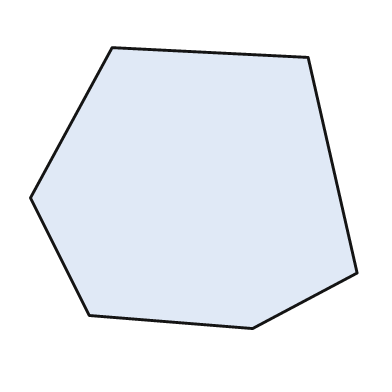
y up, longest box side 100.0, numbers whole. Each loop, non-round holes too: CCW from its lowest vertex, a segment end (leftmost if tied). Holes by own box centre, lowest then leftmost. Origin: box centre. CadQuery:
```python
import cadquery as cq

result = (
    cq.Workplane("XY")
    .moveTo(18.0, -43.0)
    .lineTo(50.0, -26.0)
    .lineTo(35.0, 40.0)
    .lineTo(-25.0, 43.0)
    .lineTo(-50.0, -3.0)
    .lineTo(-32.0, -39.0)
    .close()
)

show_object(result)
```